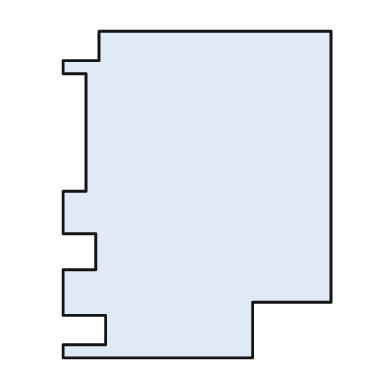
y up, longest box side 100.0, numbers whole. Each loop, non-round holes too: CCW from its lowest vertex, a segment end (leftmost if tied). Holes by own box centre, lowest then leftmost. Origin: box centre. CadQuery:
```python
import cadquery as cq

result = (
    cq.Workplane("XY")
    .moveTo(-41.0, -50.0)
    .lineTo(17.0, -50.0)
    .lineTo(17.0, -33.0)
    .lineTo(41.0, -33.0)
    .lineTo(41.0, 50.0)
    .lineTo(-30.0, 50.0)
    .lineTo(-30.0, 41.0)
    .lineTo(-41.0, 41.0)
    .lineTo(-41.0, 37.0)
    .lineTo(-34.0, 37.0)
    .lineTo(-34.0, 1.0)
    .lineTo(-41.0, 1.0)
    .lineTo(-41.0, -12.0)
    .lineTo(-31.0, -12.0)
    .lineTo(-31.0, -23.0)
    .lineTo(-41.0, -23.0)
    .lineTo(-41.0, -37.0)
    .lineTo(-28.0, -37.0)
    .lineTo(-28.0, -46.0)
    .lineTo(-41.0, -46.0)
    .close()
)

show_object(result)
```